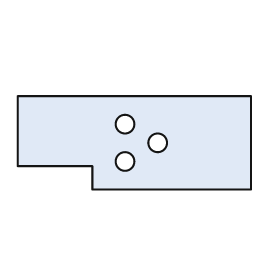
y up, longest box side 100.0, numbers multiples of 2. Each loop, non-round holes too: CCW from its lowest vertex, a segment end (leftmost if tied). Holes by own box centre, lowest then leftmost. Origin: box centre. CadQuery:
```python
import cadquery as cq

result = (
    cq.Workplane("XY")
    .moveTo(-18.0, -20.0)
    .lineTo(50.0, -20.0)
    .lineTo(50.0, 20.0)
    .lineTo(-50.0, 20.0)
    .lineTo(-50.0, -10.0)
    .lineTo(-18.0, -10.0)
    .close()
    .moveTo(-4.0, -8.0)
    .circle(4.0)
    .moveTo(10.0, 0.0)
    .circle(4.0)
    .moveTo(-4.0, 8.0)
    .circle(4.0)
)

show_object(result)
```